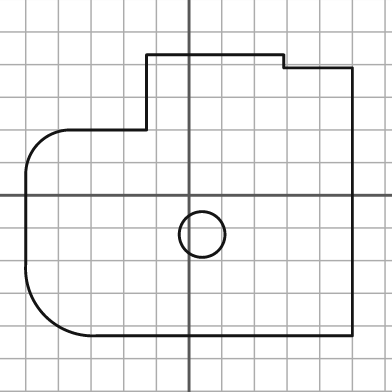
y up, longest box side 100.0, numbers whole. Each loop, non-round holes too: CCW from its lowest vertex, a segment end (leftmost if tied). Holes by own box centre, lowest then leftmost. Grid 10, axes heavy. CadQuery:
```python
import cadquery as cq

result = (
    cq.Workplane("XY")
    .moveTo(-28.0, -43.0)
    .lineTo(50.0, -43.0)
    .lineTo(50.0, 39.0)
    .lineTo(29.0, 39.0)
    .lineTo(29.0, 43.0)
    .lineTo(-13.0, 43.0)
    .lineTo(-13.0, 20.0)
    .lineTo(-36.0, 20.0)
    .threePointArc((-46.0, 16.0), (-50.0, 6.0))
    .lineTo(-50.0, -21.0)
    .threePointArc((-44.0, -37.0), (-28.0, -43.0))
    .close()
    .moveTo(4.0, -12.0)
    .circle(7.0)
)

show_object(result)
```